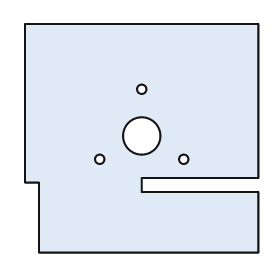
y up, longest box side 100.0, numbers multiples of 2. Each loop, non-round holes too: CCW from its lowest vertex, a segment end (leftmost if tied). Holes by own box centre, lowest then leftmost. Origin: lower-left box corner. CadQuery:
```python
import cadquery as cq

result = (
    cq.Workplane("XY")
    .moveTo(6.0, 0.0)
    .lineTo(100.0, 0.0)
    .lineTo(100.0, 26.0)
    .lineTo(50.0, 26.0)
    .lineTo(50.0, 32.0)
    .lineTo(100.0, 32.0)
    .lineTo(100.0, 98.0)
    .lineTo(0.0, 98.0)
    .lineTo(0.0, 30.0)
    .lineTo(6.0, 30.0)
    .close()
    .moveTo(32.0, 40.0)
    .circle(2.0)
    .moveTo(68.0, 40.0)
    .circle(2.0)
    .moveTo(50.0, 50.0)
    .circle(8.0)
    .moveTo(50.0, 70.0)
    .circle(2.0)
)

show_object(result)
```